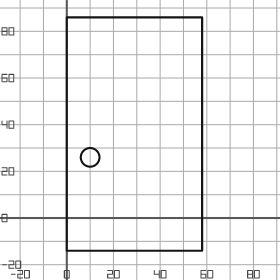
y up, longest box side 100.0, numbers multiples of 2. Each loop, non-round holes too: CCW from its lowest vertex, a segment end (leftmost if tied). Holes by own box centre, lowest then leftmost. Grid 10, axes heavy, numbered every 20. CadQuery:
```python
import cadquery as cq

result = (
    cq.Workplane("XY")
    .moveTo(0.0, -14.0)
    .lineTo(58.0, -14.0)
    .lineTo(58.0, 86.0)
    .lineTo(0.0, 86.0)
    .close()
    .moveTo(10.0, 26.0)
    .circle(4.0)
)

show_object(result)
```